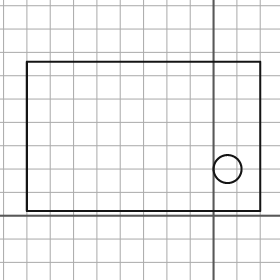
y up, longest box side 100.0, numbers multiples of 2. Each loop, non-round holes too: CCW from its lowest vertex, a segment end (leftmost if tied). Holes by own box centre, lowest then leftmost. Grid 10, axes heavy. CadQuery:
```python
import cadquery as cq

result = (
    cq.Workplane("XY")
    .moveTo(-80.0, 2.0)
    .lineTo(20.0, 2.0)
    .lineTo(20.0, 66.0)
    .lineTo(-80.0, 66.0)
    .close()
    .moveTo(6.0, 20.0)
    .circle(6.0)
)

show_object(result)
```